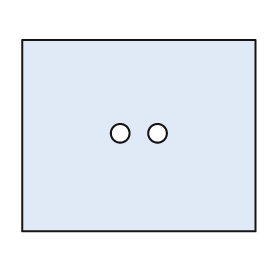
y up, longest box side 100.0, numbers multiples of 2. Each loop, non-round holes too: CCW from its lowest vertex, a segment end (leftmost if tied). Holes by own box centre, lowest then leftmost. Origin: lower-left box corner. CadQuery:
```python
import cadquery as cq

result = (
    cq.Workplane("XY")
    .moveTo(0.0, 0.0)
    .lineTo(100.0, 0.0)
    .lineTo(100.0, 82.0)
    .lineTo(0.0, 82.0)
    .close()
    .moveTo(42.0, 42.0)
    .circle(4.0)
    .moveTo(58.0, 42.0)
    .circle(4.0)
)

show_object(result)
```